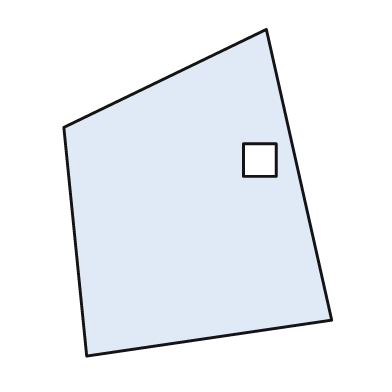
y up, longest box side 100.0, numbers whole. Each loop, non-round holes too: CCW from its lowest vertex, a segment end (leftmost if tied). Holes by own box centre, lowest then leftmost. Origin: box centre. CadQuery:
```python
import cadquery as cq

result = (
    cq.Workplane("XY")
    .moveTo(-34.0, -50.0)
    .lineTo(41.0, -39.0)
    .lineTo(21.0, 50.0)
    .lineTo(-41.0, 20.0)
    .close()
    .moveTo(14.0, 5.0)
    .lineTo(24.0, 5.0)
    .lineTo(24.0, 15.0)
    .lineTo(14.0, 15.0)
    .close()
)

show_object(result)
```